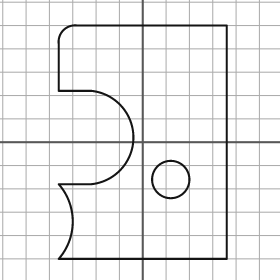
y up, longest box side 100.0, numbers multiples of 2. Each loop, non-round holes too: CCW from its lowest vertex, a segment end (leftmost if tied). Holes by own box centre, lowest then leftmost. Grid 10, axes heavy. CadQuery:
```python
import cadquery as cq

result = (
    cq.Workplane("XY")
    .moveTo(-36.0, -50.0)
    .lineTo(36.0, -50.0)
    .lineTo(36.0, 50.0)
    .lineTo(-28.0, 50.0)
    .threePointArc((-34.0, 48.0), (-36.0, 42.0))
    .lineTo(-36.0, 22.0)
    .lineTo(-22.0, 22.0)
    .threePointArc((-4.0, 2.0), (-22.0, -18.0))
    .lineTo(-36.0, -18.0)
    .threePointArc((-30.0, -34.0), (-36.0, -50.0))
    .close()
    .moveTo(12.0, -16.0)
    .circle(8.0)
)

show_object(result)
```